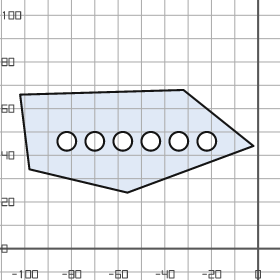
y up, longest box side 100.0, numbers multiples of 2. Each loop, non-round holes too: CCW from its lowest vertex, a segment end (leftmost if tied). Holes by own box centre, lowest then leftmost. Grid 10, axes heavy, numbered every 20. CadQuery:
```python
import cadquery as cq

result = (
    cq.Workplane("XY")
    .moveTo(-56.0, 24.0)
    .lineTo(-2.0, 44.0)
    .lineTo(-32.0, 68.0)
    .lineTo(-102.0, 66.0)
    .lineTo(-98.0, 34.0)
    .close()
    .moveTo(-82.0, 46.0)
    .circle(4.0)
    .moveTo(-70.0, 46.0)
    .circle(4.0)
    .moveTo(-58.0, 46.0)
    .circle(4.0)
    .moveTo(-46.0, 46.0)
    .circle(4.0)
    .moveTo(-34.0, 46.0)
    .circle(4.0)
    .moveTo(-22.0, 46.0)
    .circle(4.0)
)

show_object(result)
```